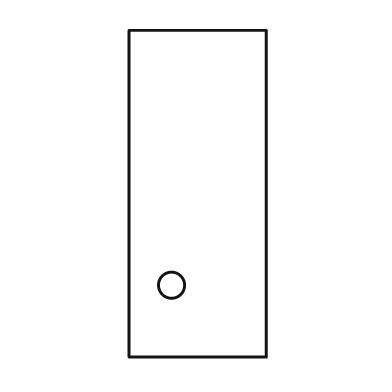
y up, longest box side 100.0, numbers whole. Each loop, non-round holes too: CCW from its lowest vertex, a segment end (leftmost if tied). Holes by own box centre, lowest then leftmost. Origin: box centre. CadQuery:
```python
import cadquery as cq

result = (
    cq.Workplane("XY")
    .moveTo(-21.0, -50.0)
    .lineTo(21.0, -50.0)
    .lineTo(21.0, 50.0)
    .lineTo(-21.0, 50.0)
    .close()
    .moveTo(-8.0, -28.0)
    .circle(4.0)
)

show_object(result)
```